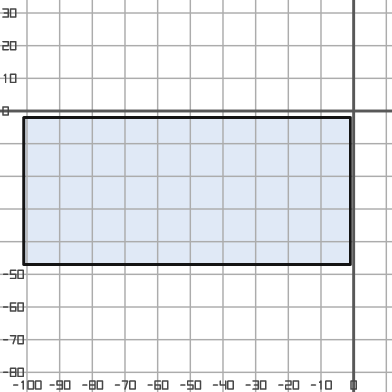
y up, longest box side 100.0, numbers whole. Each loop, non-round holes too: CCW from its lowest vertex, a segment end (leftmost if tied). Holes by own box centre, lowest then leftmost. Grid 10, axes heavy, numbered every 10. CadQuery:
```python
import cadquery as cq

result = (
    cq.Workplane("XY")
    .moveTo(-101.0, -47.0)
    .lineTo(-1.0, -47.0)
    .lineTo(-1.0, -2.0)
    .lineTo(-101.0, -2.0)
    .close()
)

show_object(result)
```